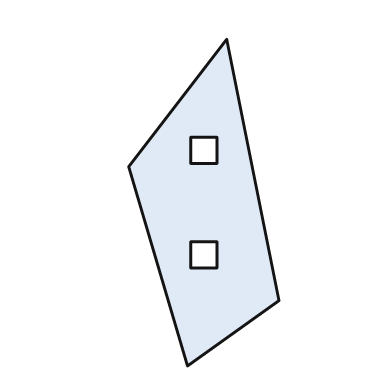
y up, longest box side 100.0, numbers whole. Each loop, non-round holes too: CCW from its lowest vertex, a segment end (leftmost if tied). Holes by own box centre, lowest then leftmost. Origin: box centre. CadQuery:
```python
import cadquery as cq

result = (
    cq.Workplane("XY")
    .moveTo(-5.0, -50.0)
    .lineTo(23.0, -30.0)
    .lineTo(7.0, 50.0)
    .lineTo(-23.0, 11.0)
    .close()
    .moveTo(-4.0, -20.0)
    .lineTo(4.0, -20.0)
    .lineTo(4.0, -12.0)
    .lineTo(-4.0, -12.0)
    .close()
    .moveTo(-4.0, 12.0)
    .lineTo(4.0, 12.0)
    .lineTo(4.0, 20.0)
    .lineTo(-4.0, 20.0)
    .close()
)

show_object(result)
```